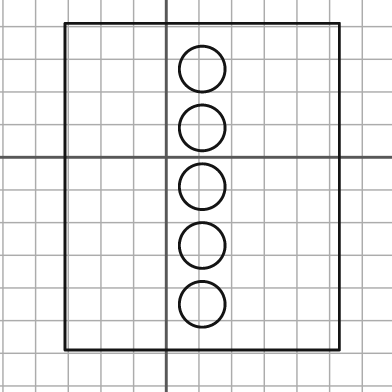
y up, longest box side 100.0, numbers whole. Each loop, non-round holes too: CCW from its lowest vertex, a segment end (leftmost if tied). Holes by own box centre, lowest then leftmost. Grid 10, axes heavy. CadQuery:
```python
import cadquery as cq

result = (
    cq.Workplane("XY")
    .moveTo(-31.0, -59.0)
    .lineTo(53.0, -59.0)
    .lineTo(53.0, 41.0)
    .lineTo(-31.0, 41.0)
    .close()
    .moveTo(11.0, -45.0)
    .circle(7.0)
    .moveTo(11.0, -27.0)
    .circle(7.0)
    .moveTo(11.0, -9.0)
    .circle(7.0)
    .moveTo(11.0, 9.0)
    .circle(7.0)
    .moveTo(11.0, 27.0)
    .circle(7.0)
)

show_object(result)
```